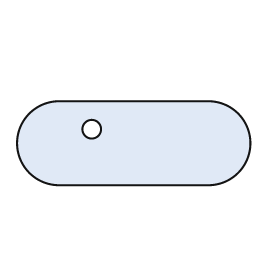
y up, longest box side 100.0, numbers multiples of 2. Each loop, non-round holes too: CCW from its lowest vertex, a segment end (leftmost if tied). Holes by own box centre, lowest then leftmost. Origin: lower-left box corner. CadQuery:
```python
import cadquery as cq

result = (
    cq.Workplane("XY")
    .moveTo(18.0, 0.0)
    .lineTo(82.0, 0.0)
    .threePointArc((100.0, 18.0), (82.0, 36.0))
    .lineTo(18.0, 36.0)
    .threePointArc((0.0, 18.0), (18.0, 0.0))
    .close()
    .moveTo(32.0, 24.0)
    .circle(4.0)
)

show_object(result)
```